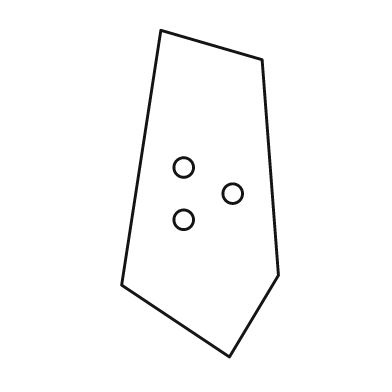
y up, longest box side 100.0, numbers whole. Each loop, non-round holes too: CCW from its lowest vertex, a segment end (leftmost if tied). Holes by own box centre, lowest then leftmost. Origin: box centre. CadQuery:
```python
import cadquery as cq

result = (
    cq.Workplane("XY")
    .moveTo(9.0, -50.0)
    .lineTo(24.0, -25.0)
    .lineTo(19.0, 41.0)
    .lineTo(-12.0, 50.0)
    .lineTo(-24.0, -28.0)
    .close()
    .moveTo(-5.0, -8.0)
    .circle(3.0)
    .moveTo(10.0, 0.0)
    .circle(3.0)
    .moveTo(-5.0, 8.0)
    .circle(3.0)
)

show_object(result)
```